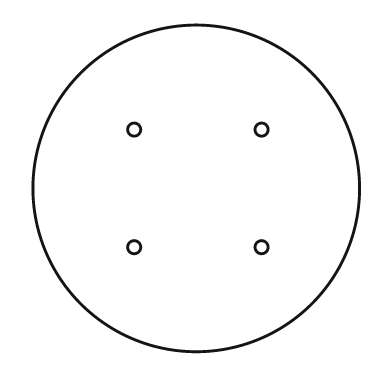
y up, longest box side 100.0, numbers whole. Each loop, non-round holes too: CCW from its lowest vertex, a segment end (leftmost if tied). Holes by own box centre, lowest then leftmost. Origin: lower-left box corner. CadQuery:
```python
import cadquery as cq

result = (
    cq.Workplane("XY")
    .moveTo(50.0, 50.0)
    .circle(50.0)
    .moveTo(31.0, 32.0)
    .circle(2.0)
    .moveTo(70.0, 32.0)
    .circle(2.0)
    .moveTo(31.0, 68.0)
    .circle(2.0)
    .moveTo(70.0, 68.0)
    .circle(2.0)
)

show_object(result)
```